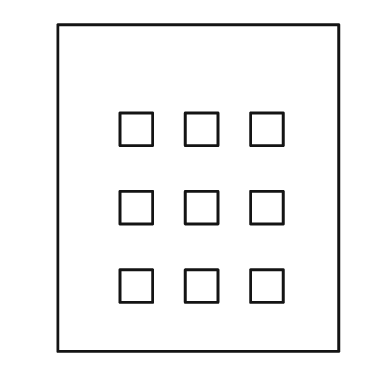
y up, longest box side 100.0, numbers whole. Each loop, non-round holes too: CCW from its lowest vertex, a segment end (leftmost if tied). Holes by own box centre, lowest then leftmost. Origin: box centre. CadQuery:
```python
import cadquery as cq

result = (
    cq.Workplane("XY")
    .moveTo(-43.0, -50.0)
    .lineTo(43.0, -50.0)
    .lineTo(43.0, 50.0)
    .lineTo(-43.0, 50.0)
    .close()
    .moveTo(-24.0, -35.0)
    .lineTo(-14.0, -35.0)
    .lineTo(-14.0, -25.0)
    .lineTo(-24.0, -25.0)
    .close()
    .moveTo(-4.0, -35.0)
    .lineTo(6.0, -35.0)
    .lineTo(6.0, -25.0)
    .lineTo(-4.0, -25.0)
    .close()
    .moveTo(16.0, -35.0)
    .lineTo(26.0, -35.0)
    .lineTo(26.0, -25.0)
    .lineTo(16.0, -25.0)
    .close()
    .moveTo(-24.0, -11.0)
    .lineTo(-14.0, -11.0)
    .lineTo(-14.0, -1.0)
    .lineTo(-24.0, -1.0)
    .close()
    .moveTo(-4.0, -11.0)
    .lineTo(6.0, -11.0)
    .lineTo(6.0, -1.0)
    .lineTo(-4.0, -1.0)
    .close()
    .moveTo(16.0, -11.0)
    .lineTo(26.0, -11.0)
    .lineTo(26.0, -1.0)
    .lineTo(16.0, -1.0)
    .close()
    .moveTo(-24.0, 13.0)
    .lineTo(-14.0, 13.0)
    .lineTo(-14.0, 23.0)
    .lineTo(-24.0, 23.0)
    .close()
    .moveTo(-4.0, 13.0)
    .lineTo(6.0, 13.0)
    .lineTo(6.0, 23.0)
    .lineTo(-4.0, 23.0)
    .close()
    .moveTo(16.0, 13.0)
    .lineTo(26.0, 13.0)
    .lineTo(26.0, 23.0)
    .lineTo(16.0, 23.0)
    .close()
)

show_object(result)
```